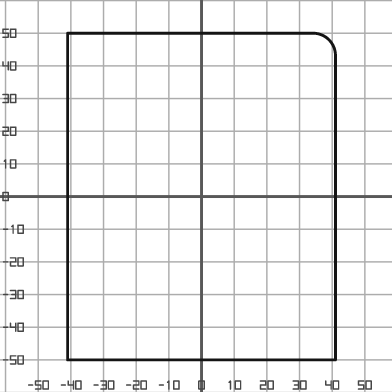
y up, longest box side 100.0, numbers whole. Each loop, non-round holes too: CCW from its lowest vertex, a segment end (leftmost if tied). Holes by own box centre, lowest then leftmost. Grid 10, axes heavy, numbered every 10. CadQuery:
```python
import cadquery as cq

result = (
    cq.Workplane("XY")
    .moveTo(-41.0, -50.0)
    .lineTo(41.0, -50.0)
    .lineTo(41.0, 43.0)
    .threePointArc((39.0, 48.0), (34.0, 50.0))
    .lineTo(-41.0, 50.0)
    .close()
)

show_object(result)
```